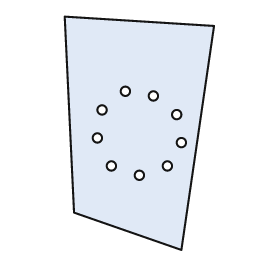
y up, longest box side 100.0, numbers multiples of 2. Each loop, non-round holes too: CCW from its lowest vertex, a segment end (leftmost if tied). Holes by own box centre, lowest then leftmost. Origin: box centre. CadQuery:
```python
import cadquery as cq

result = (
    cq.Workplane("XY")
    .moveTo(18.0, -50.0)
    .lineTo(32.0, 46.0)
    .lineTo(-32.0, 50.0)
    .lineTo(-28.0, -34.0)
    .close()
    .moveTo(0.0, -18.0)
    .circle(2.0)
    .moveTo(-12.0, -14.0)
    .circle(2.0)
    .moveTo(12.0, -14.0)
    .circle(2.0)
    .moveTo(18.0, -4.0)
    .circle(2.0)
    .moveTo(-18.0, -2.0)
    .circle(2.0)
    .moveTo(16.0, 8.0)
    .circle(2.0)
    .moveTo(-16.0, 10.0)
    .circle(2.0)
    .moveTo(6.0, 16.0)
    .circle(2.0)
    .moveTo(-6.0, 18.0)
    .circle(2.0)
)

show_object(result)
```